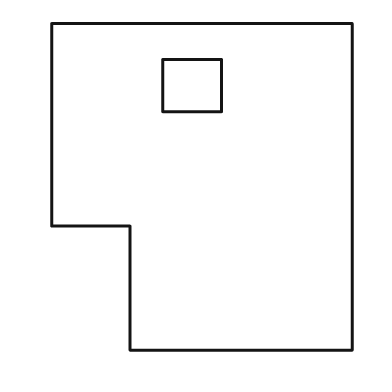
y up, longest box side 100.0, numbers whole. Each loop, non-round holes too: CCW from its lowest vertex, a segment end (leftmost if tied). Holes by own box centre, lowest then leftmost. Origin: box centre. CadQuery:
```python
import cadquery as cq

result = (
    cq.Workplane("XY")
    .moveTo(-22.0, -50.0)
    .lineTo(46.0, -50.0)
    .lineTo(46.0, 50.0)
    .lineTo(-46.0, 50.0)
    .lineTo(-46.0, -12.0)
    .lineTo(-22.0, -12.0)
    .close()
    .moveTo(-12.0, 23.0)
    .lineTo(6.0, 23.0)
    .lineTo(6.0, 39.0)
    .lineTo(-12.0, 39.0)
    .close()
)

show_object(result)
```